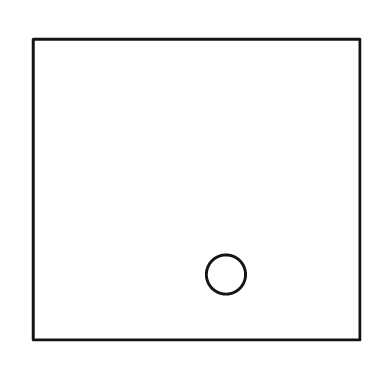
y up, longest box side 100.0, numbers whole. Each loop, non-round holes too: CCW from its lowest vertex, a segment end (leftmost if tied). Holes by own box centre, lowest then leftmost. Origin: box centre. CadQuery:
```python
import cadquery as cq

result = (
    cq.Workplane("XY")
    .moveTo(-50.0, -46.0)
    .lineTo(50.0, -46.0)
    .lineTo(50.0, 46.0)
    .lineTo(-50.0, 46.0)
    .close()
    .moveTo(9.0, -26.0)
    .circle(6.0)
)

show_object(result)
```